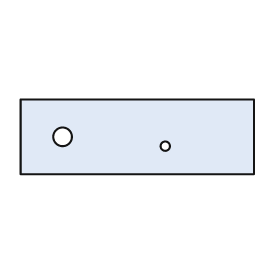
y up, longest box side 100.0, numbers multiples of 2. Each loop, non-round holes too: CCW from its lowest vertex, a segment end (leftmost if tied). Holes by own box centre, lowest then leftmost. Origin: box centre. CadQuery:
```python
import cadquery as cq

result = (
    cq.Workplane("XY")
    .moveTo(-50.0, -16.0)
    .lineTo(50.0, -16.0)
    .lineTo(50.0, 16.0)
    .lineTo(-50.0, 16.0)
    .close()
    .moveTo(12.0, -4.0)
    .circle(2.0)
    .moveTo(-32.0, 0.0)
    .circle(4.0)
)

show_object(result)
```